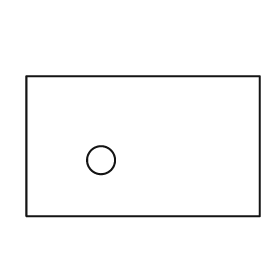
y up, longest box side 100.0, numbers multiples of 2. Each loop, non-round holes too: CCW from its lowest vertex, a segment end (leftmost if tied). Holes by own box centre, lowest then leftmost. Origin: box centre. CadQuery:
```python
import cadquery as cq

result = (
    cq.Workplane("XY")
    .moveTo(-50.0, -30.0)
    .lineTo(50.0, -30.0)
    .lineTo(50.0, 30.0)
    .lineTo(-50.0, 30.0)
    .close()
    .moveTo(-18.0, -6.0)
    .circle(6.0)
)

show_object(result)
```